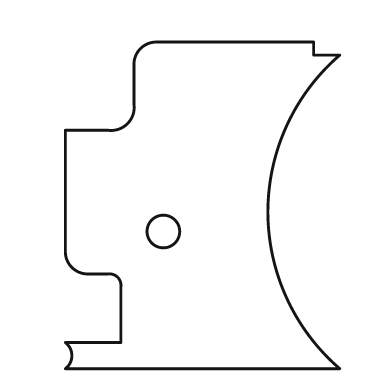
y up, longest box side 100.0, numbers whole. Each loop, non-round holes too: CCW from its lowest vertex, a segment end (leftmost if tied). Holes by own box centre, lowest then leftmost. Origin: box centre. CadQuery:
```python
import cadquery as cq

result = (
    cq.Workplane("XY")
    .moveTo(-42.0, -50.0)
    .lineTo(42.0, -50.0)
    .threePointArc((20.0, -2.0), (42.0, 46.0))
    .lineTo(34.0, 46.0)
    .lineTo(34.0, 50.0)
    .lineTo(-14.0, 50.0)
    .threePointArc((-19.0, 48.0), (-21.0, 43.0))
    .lineTo(-21.0, 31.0)
    .threePointArc((-23.0, 25.0), (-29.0, 23.0))
    .lineTo(-42.0, 23.0)
    .lineTo(-42.0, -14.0)
    .threePointArc((-40.0, -19.0), (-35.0, -21.0))
    .lineTo(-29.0, -21.0)
    .threePointArc((-26.0, -22.0), (-25.0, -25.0))
    .lineTo(-25.0, -42.0)
    .lineTo(-42.0, -42.0)
    .threePointArc((-40.0, -46.0), (-42.0, -50.0))
    .close()
    .moveTo(-12.0, -8.0)
    .circle(5.0)
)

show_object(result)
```